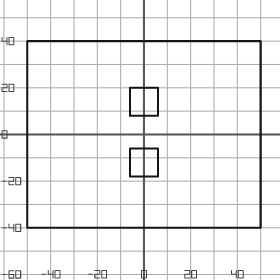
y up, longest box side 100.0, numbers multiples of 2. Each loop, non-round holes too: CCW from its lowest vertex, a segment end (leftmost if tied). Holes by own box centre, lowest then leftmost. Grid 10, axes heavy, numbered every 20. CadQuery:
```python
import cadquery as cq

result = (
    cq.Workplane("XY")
    .moveTo(-50.0, -40.0)
    .lineTo(50.0, -40.0)
    .lineTo(50.0, 40.0)
    .lineTo(-50.0, 40.0)
    .close()
    .moveTo(-6.0, -18.0)
    .lineTo(6.0, -18.0)
    .lineTo(6.0, -6.0)
    .lineTo(-6.0, -6.0)
    .close()
    .moveTo(-6.0, 8.0)
    .lineTo(6.0, 8.0)
    .lineTo(6.0, 20.0)
    .lineTo(-6.0, 20.0)
    .close()
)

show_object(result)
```